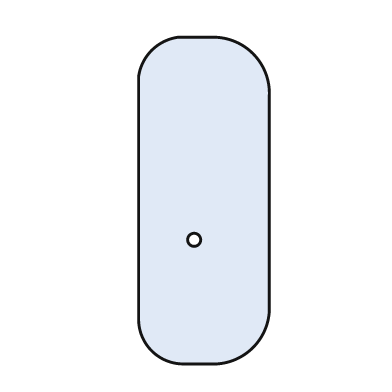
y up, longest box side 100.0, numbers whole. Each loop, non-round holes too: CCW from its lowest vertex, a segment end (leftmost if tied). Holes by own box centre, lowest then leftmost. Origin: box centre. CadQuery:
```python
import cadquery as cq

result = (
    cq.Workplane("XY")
    .moveTo(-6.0, -50.0)
    .lineTo(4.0, -50.0)
    .threePointArc((15.0, -45.0), (20.0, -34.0))
    .lineTo(20.0, 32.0)
    .threePointArc((15.0, 45.0), (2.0, 50.0))
    .lineTo(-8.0, 50.0)
    .threePointArc((-16.0, 46.0), (-20.0, 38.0))
    .lineTo(-20.0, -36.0)
    .threePointArc((-16.0, -46.0), (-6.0, -50.0))
    .close()
    .moveTo(-3.0, -12.0)
    .circle(2.0)
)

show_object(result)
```